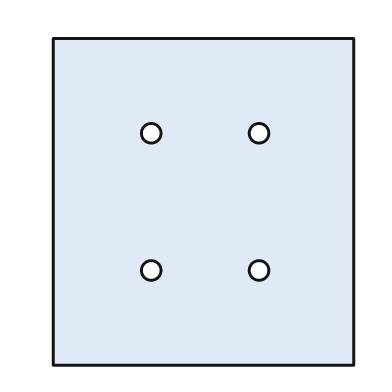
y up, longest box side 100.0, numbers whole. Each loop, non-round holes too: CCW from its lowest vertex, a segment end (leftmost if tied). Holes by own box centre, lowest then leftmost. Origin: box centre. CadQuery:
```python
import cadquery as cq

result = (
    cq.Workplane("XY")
    .moveTo(-46.0, -50.0)
    .lineTo(46.0, -50.0)
    .lineTo(46.0, 50.0)
    .lineTo(-46.0, 50.0)
    .close()
    .moveTo(-16.0, -21.0)
    .circle(3.0)
    .moveTo(17.0, -21.0)
    .circle(3.0)
    .moveTo(-16.0, 21.0)
    .circle(3.0)
    .moveTo(17.0, 21.0)
    .circle(3.0)
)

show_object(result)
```